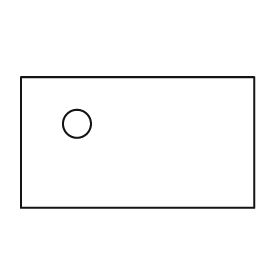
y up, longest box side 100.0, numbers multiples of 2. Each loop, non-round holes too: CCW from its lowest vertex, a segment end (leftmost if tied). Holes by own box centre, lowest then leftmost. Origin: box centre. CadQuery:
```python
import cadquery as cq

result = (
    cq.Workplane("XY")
    .moveTo(-50.0, -28.0)
    .lineTo(50.0, -28.0)
    .lineTo(50.0, 28.0)
    .lineTo(-50.0, 28.0)
    .close()
    .moveTo(-26.0, 8.0)
    .circle(6.0)
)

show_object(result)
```